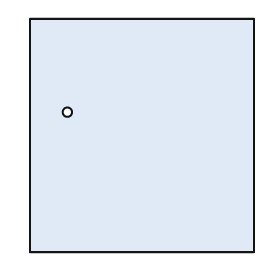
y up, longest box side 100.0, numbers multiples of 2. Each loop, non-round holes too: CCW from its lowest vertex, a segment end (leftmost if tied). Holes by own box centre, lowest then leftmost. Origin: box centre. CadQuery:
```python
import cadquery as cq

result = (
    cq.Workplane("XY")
    .moveTo(-48.0, -50.0)
    .lineTo(48.0, -50.0)
    .lineTo(48.0, 50.0)
    .lineTo(-48.0, 50.0)
    .close()
    .moveTo(-32.0, 10.0)
    .circle(2.0)
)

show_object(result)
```